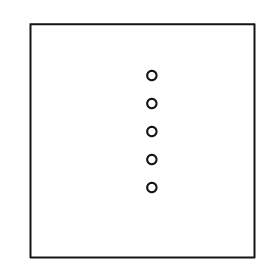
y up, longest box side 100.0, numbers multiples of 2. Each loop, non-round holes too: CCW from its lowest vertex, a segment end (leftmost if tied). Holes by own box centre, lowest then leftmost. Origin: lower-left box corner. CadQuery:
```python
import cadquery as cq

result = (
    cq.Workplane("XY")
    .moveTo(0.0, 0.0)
    .lineTo(96.0, 0.0)
    .lineTo(96.0, 100.0)
    .lineTo(0.0, 100.0)
    .close()
    .moveTo(52.0, 30.0)
    .circle(2.0)
    .moveTo(52.0, 42.0)
    .circle(2.0)
    .moveTo(52.0, 54.0)
    .circle(2.0)
    .moveTo(52.0, 66.0)
    .circle(2.0)
    .moveTo(52.0, 78.0)
    .circle(2.0)
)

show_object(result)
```